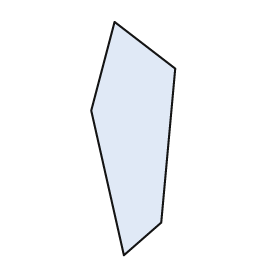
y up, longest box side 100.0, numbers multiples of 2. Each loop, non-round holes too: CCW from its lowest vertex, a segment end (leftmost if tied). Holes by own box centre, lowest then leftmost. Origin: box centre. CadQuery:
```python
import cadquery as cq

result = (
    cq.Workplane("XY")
    .moveTo(-4.0, -50.0)
    .lineTo(12.0, -36.0)
    .lineTo(18.0, 30.0)
    .lineTo(-8.0, 50.0)
    .lineTo(-18.0, 12.0)
    .close()
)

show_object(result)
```